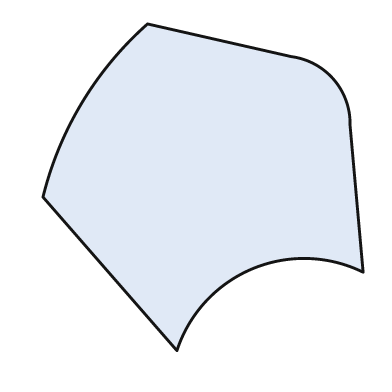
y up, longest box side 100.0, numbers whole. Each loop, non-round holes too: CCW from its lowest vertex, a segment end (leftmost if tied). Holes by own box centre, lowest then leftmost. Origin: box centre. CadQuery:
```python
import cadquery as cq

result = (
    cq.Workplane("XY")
    .moveTo(-8.0, -50.0)
    .threePointArc((15.0, -25.0), (49.0, -26.0))
    .lineTo(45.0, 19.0)
    .threePointArc((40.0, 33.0), (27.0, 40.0))
    .lineTo(-17.0, 50.0)
    .threePointArc((-37.0, 26.0), (-49.0, -3.0))
    .close()
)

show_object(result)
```